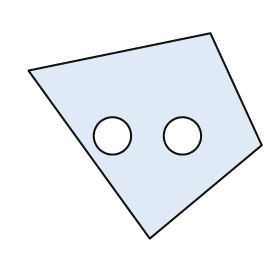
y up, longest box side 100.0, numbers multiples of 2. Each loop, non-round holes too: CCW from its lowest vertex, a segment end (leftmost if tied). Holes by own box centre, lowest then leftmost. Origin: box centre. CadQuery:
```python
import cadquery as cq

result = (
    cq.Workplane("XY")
    .moveTo(2.0, -44.0)
    .lineTo(50.0, -4.0)
    .lineTo(28.0, 44.0)
    .lineTo(-50.0, 28.0)
    .close()
    .moveTo(-14.0, 0.0)
    .circle(8.0)
    .moveTo(16.0, 0.0)
    .circle(8.0)
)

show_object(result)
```